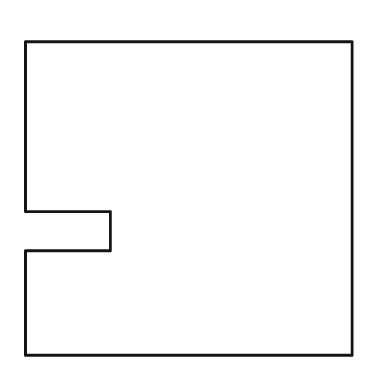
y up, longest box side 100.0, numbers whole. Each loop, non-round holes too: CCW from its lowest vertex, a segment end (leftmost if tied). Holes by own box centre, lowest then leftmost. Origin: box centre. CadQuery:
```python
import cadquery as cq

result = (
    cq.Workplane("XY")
    .moveTo(-50.0, -48.0)
    .lineTo(50.0, -48.0)
    .lineTo(50.0, 48.0)
    .lineTo(-50.0, 48.0)
    .lineTo(-50.0, -4.0)
    .lineTo(-24.0, -4.0)
    .lineTo(-24.0, -16.0)
    .lineTo(-50.0, -16.0)
    .close()
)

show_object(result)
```